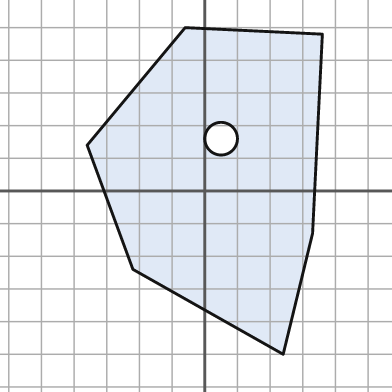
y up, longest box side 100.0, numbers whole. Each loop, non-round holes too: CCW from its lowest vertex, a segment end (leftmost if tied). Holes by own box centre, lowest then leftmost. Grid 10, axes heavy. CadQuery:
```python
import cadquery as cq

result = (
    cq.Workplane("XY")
    .moveTo(24.0, -50.0)
    .lineTo(33.0, -13.0)
    .lineTo(36.0, 48.0)
    .lineTo(-6.0, 50.0)
    .lineTo(-36.0, 14.0)
    .lineTo(-22.0, -24.0)
    .close()
    .moveTo(5.0, 16.0)
    .circle(5.0)
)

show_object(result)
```